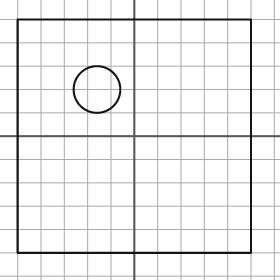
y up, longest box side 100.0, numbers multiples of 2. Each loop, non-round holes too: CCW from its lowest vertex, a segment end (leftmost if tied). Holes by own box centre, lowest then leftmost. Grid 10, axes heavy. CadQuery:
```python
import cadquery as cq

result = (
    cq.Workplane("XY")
    .moveTo(-50.0, -50.0)
    .lineTo(50.0, -50.0)
    .lineTo(50.0, 50.0)
    .lineTo(-50.0, 50.0)
    .close()
    .moveTo(-16.0, 20.0)
    .circle(10.0)
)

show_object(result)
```